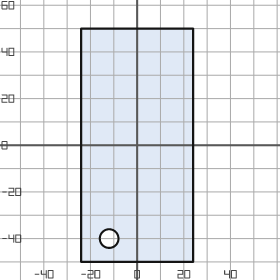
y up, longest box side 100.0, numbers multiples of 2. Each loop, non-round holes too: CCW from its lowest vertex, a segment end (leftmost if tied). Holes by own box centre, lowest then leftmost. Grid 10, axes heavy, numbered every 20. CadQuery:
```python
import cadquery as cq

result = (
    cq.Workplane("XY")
    .moveTo(-24.0, -50.0)
    .lineTo(24.0, -50.0)
    .lineTo(24.0, 50.0)
    .lineTo(-24.0, 50.0)
    .close()
    .moveTo(-12.0, -40.0)
    .circle(4.0)
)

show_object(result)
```